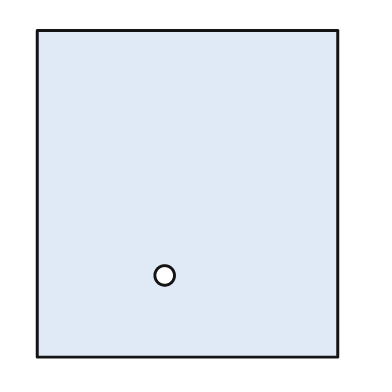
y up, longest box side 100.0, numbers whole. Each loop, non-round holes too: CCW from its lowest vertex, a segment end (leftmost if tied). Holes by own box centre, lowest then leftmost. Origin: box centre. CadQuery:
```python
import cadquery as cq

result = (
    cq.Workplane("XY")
    .moveTo(-46.0, -50.0)
    .lineTo(46.0, -50.0)
    .lineTo(46.0, 50.0)
    .lineTo(-46.0, 50.0)
    .close()
    .moveTo(-7.0, -25.0)
    .circle(3.0)
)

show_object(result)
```